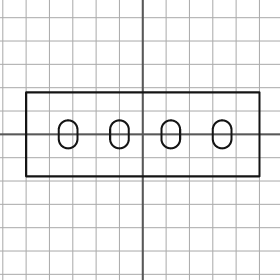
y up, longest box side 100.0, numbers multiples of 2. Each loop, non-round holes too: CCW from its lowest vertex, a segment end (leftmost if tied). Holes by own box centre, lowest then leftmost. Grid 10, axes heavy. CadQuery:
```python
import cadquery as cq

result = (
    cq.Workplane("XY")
    .moveTo(-50.0, -18.0)
    .lineTo(50.0, -18.0)
    .lineTo(50.0, 18.0)
    .lineTo(-50.0, 18.0)
    .close()
    .moveTo(-36.0, -2.0)
    .threePointArc((-32.0, -6.0), (-28.0, -2.0))
    .lineTo(-28.0, 2.0)
    .threePointArc((-32.0, 6.0), (-36.0, 2.0))
    .close()
    .moveTo(-14.0, -2.0)
    .threePointArc((-10.0, -6.0), (-6.0, -2.0))
    .lineTo(-6.0, 2.0)
    .threePointArc((-10.0, 6.0), (-14.0, 2.0))
    .close()
    .moveTo(8.0, -2.0)
    .threePointArc((12.0, -6.0), (16.0, -2.0))
    .lineTo(16.0, 2.0)
    .threePointArc((12.0, 6.0), (8.0, 2.0))
    .close()
    .moveTo(30.0, -2.0)
    .threePointArc((34.0, -6.0), (38.0, -2.0))
    .lineTo(38.0, 2.0)
    .threePointArc((34.0, 6.0), (30.0, 2.0))
    .close()
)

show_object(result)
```